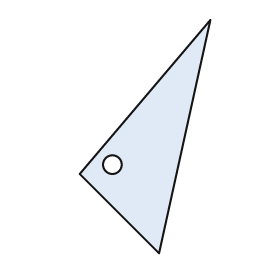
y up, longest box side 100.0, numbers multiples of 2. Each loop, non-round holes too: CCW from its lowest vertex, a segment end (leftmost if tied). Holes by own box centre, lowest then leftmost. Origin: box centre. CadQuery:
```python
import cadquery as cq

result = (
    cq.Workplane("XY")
    .moveTo(6.0, -50.0)
    .lineTo(28.0, 50.0)
    .lineTo(-28.0, -16.0)
    .close()
    .moveTo(-14.0, -12.0)
    .circle(4.0)
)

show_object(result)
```